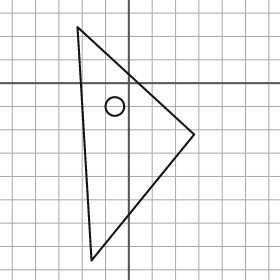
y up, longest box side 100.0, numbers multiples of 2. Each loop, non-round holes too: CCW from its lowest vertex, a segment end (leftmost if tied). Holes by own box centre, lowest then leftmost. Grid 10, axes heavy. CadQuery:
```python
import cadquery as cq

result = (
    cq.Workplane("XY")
    .moveTo(-16.0, -76.0)
    .lineTo(28.0, -22.0)
    .lineTo(-22.0, 24.0)
    .close()
    .moveTo(-6.0, -10.0)
    .circle(4.0)
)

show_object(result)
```